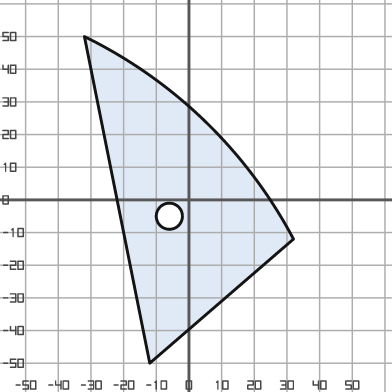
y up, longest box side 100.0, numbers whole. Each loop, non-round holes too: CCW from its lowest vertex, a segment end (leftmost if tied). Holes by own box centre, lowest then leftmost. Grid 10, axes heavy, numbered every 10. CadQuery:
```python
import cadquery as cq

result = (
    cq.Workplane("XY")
    .moveTo(-12.0, -50.0)
    .lineTo(32.0, -12.0)
    .threePointArc((5.0, 24.0), (-32.0, 50.0))
    .close()
    .moveTo(-6.0, -5.0)
    .circle(4.0)
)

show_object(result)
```